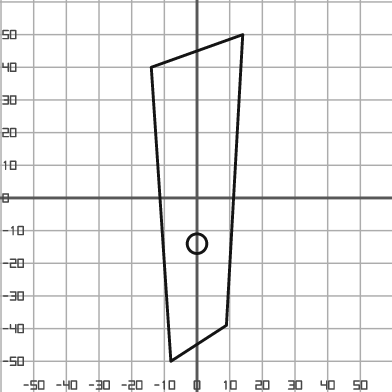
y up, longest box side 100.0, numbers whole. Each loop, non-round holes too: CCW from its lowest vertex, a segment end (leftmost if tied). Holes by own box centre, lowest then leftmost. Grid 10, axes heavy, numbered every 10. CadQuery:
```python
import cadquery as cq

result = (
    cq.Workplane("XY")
    .moveTo(-8.0, -50.0)
    .lineTo(9.0, -39.0)
    .lineTo(14.0, 50.0)
    .lineTo(-14.0, 40.0)
    .close()
    .moveTo(0.0, -14.0)
    .circle(3.0)
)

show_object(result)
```